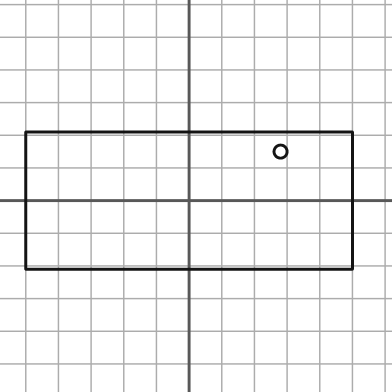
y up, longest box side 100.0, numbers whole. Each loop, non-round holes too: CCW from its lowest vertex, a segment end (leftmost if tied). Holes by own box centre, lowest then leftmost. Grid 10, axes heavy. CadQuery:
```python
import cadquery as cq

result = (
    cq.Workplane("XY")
    .moveTo(-50.0, -21.0)
    .lineTo(50.0, -21.0)
    .lineTo(50.0, 21.0)
    .lineTo(-50.0, 21.0)
    .close()
    .moveTo(28.0, 15.0)
    .circle(2.0)
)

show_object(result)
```